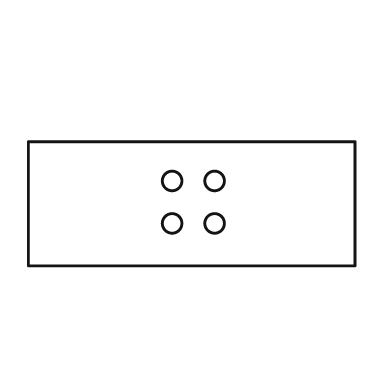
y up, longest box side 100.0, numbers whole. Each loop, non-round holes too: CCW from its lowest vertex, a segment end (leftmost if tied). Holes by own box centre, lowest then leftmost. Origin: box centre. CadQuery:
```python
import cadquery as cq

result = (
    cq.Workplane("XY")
    .moveTo(-50.0, -19.0)
    .lineTo(50.0, -19.0)
    .lineTo(50.0, 19.0)
    .lineTo(-50.0, 19.0)
    .close()
    .moveTo(-6.0, -6.0)
    .circle(3.0)
    .moveTo(7.0, -6.0)
    .circle(3.0)
    .moveTo(-6.0, 7.0)
    .circle(3.0)
    .moveTo(7.0, 7.0)
    .circle(3.0)
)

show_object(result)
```